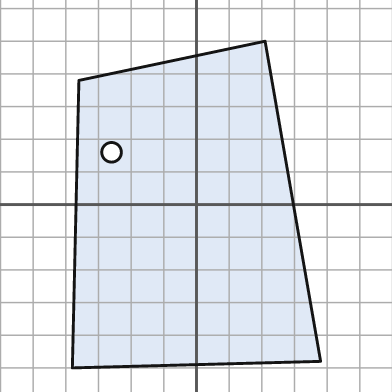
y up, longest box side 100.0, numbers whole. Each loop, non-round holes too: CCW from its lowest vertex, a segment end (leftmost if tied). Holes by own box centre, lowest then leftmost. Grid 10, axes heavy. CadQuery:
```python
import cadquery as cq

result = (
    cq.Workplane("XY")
    .moveTo(-38.0, -50.0)
    .lineTo(38.0, -48.0)
    .lineTo(21.0, 50.0)
    .lineTo(-36.0, 38.0)
    .close()
    .moveTo(-26.0, 16.0)
    .circle(3.0)
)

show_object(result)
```